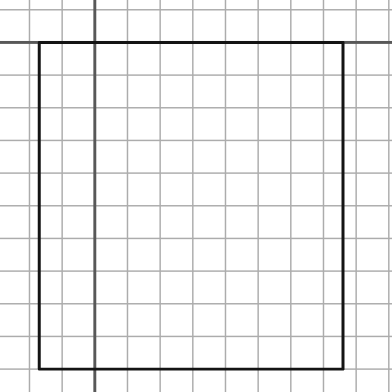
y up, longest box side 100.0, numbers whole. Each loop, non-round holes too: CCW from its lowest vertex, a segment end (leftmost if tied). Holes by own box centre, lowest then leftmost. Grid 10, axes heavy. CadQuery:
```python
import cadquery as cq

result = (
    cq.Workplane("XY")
    .moveTo(-17.0, -100.0)
    .lineTo(76.0, -100.0)
    .lineTo(76.0, 0.0)
    .lineTo(-17.0, 0.0)
    .close()
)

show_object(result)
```